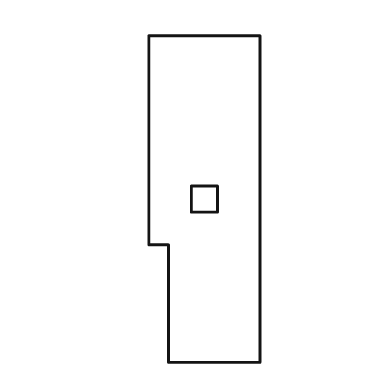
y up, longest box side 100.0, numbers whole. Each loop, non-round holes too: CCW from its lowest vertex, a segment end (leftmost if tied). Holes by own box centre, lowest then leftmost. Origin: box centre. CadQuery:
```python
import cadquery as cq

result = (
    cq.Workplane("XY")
    .moveTo(-11.0, -50.0)
    .lineTo(17.0, -50.0)
    .lineTo(17.0, 50.0)
    .lineTo(-17.0, 50.0)
    .lineTo(-17.0, -14.0)
    .lineTo(-11.0, -14.0)
    .close()
    .moveTo(-4.0, -4.0)
    .lineTo(4.0, -4.0)
    .lineTo(4.0, 4.0)
    .lineTo(-4.0, 4.0)
    .close()
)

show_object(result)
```